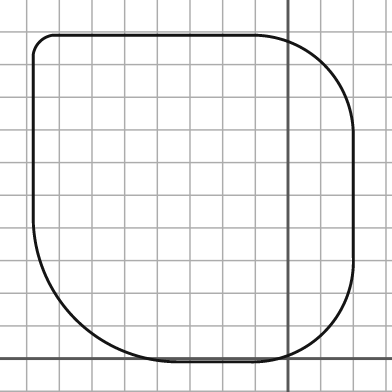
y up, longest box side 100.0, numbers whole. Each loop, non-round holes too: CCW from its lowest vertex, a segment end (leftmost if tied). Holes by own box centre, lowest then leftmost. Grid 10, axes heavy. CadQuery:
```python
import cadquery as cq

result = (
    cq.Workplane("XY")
    .moveTo(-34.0, -1.0)
    .lineTo(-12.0, -1.0)
    .threePointArc((11.0, 8.0), (20.0, 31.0))
    .lineTo(20.0, 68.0)
    .threePointArc((11.0, 90.0), (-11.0, 99.0))
    .lineTo(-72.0, 99.0)
    .threePointArc((-76.0, 97.0), (-78.0, 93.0))
    .lineTo(-78.0, 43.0)
    .threePointArc((-65.0, 12.0), (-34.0, -1.0))
    .close()
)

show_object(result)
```